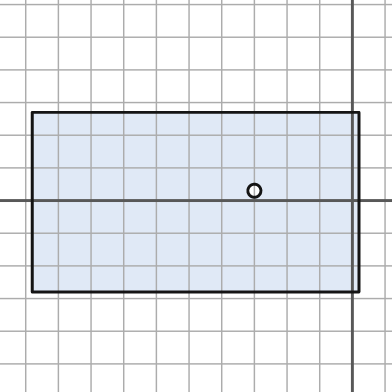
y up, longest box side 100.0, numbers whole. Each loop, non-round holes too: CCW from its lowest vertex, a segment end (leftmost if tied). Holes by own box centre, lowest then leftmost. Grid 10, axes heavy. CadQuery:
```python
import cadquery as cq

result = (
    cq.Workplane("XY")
    .moveTo(-98.0, -28.0)
    .lineTo(2.0, -28.0)
    .lineTo(2.0, 27.0)
    .lineTo(-98.0, 27.0)
    .close()
    .moveTo(-30.0, 3.0)
    .circle(2.0)
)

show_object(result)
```